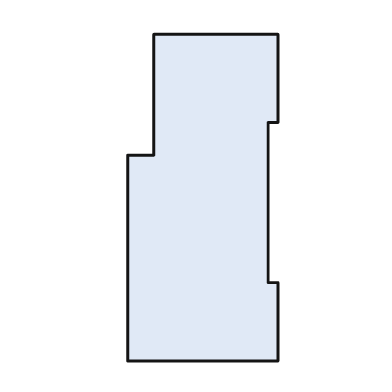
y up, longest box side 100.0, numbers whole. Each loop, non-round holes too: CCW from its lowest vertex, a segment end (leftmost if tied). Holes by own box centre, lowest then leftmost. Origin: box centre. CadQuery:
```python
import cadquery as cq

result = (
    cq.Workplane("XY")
    .moveTo(-23.0, -50.0)
    .lineTo(23.0, -50.0)
    .lineTo(23.0, -26.0)
    .lineTo(20.0, -26.0)
    .lineTo(20.0, 23.0)
    .lineTo(23.0, 23.0)
    .lineTo(23.0, 50.0)
    .lineTo(-15.0, 50.0)
    .lineTo(-15.0, 13.0)
    .lineTo(-23.0, 13.0)
    .close()
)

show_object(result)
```